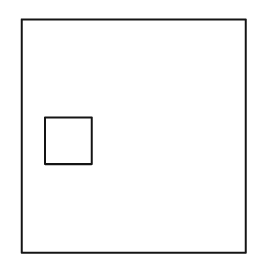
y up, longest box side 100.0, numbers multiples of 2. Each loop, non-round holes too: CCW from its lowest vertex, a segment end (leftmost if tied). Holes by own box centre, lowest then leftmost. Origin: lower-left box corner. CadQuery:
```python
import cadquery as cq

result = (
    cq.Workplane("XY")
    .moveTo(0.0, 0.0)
    .lineTo(96.0, 0.0)
    .lineTo(96.0, 100.0)
    .lineTo(0.0, 100.0)
    .close()
    .moveTo(10.0, 38.0)
    .lineTo(30.0, 38.0)
    .lineTo(30.0, 58.0)
    .lineTo(10.0, 58.0)
    .close()
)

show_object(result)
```